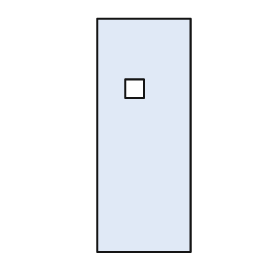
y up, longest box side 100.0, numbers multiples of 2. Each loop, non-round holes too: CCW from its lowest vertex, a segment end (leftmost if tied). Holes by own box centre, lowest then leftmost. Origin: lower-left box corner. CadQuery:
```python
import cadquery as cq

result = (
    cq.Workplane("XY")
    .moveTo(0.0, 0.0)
    .lineTo(40.0, 0.0)
    .lineTo(40.0, 100.0)
    .lineTo(0.0, 100.0)
    .close()
    .moveTo(12.0, 66.0)
    .lineTo(20.0, 66.0)
    .lineTo(20.0, 74.0)
    .lineTo(12.0, 74.0)
    .close()
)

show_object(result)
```